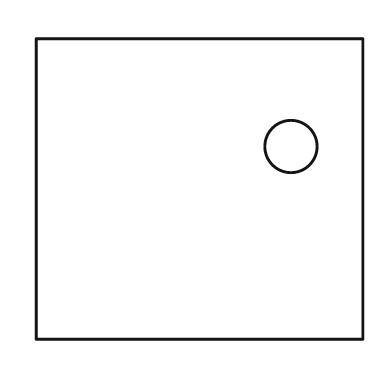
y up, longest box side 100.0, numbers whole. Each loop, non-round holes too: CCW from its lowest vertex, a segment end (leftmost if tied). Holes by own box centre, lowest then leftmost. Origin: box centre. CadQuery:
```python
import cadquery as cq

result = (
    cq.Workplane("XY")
    .moveTo(-50.0, -46.0)
    .lineTo(50.0, -46.0)
    .lineTo(50.0, 46.0)
    .lineTo(-50.0, 46.0)
    .close()
    .moveTo(28.0, 13.0)
    .circle(8.0)
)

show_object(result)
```